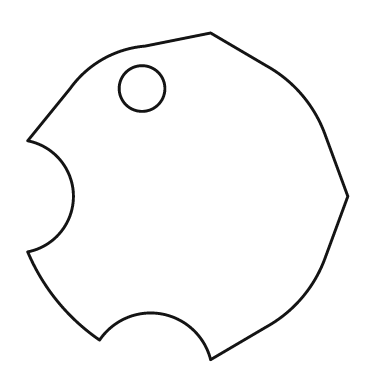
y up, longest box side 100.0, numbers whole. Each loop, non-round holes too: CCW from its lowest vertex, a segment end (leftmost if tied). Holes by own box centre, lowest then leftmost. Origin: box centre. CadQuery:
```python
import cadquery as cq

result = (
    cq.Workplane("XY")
    .moveTo(7.0, -50.0)
    .lineTo(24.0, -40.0)
    .threePointArc((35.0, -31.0), (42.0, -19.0))
    .lineTo(49.0, 0.0)
    .lineTo(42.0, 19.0)
    .threePointArc((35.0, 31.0), (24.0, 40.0))
    .lineTo(7.0, 50.0)
    .lineTo(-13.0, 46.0)
    .threePointArc((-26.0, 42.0), (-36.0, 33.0))
    .lineTo(-49.0, 17.0)
    .threePointArc((-35.0, 0.0), (-49.0, -17.0))
    .threePointArc((-40.0, -32.0), (-27.0, -44.0))
    .threePointArc((-8.0, -36.0), (7.0, -50.0))
    .close()
    .moveTo(-14.0, 33.0)
    .circle(7.0)
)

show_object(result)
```